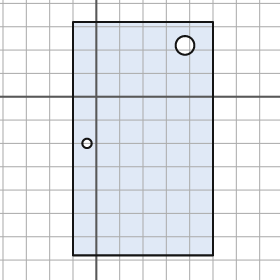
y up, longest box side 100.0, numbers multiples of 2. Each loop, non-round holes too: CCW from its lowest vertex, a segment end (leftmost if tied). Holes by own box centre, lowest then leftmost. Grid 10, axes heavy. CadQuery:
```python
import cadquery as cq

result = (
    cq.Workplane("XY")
    .moveTo(-10.0, -68.0)
    .lineTo(50.0, -68.0)
    .lineTo(50.0, 32.0)
    .lineTo(-10.0, 32.0)
    .close()
    .moveTo(-4.0, -20.0)
    .circle(2.0)
    .moveTo(38.0, 22.0)
    .circle(4.0)
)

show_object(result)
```